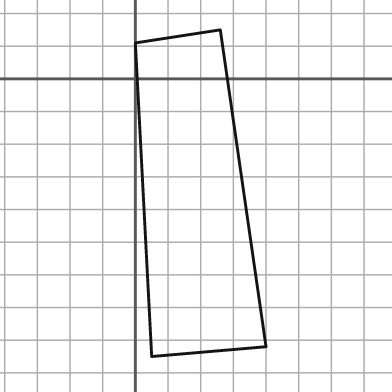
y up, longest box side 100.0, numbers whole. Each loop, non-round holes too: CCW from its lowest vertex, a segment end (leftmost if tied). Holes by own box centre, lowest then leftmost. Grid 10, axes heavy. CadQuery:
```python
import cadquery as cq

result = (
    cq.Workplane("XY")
    .moveTo(5.0, -85.0)
    .lineTo(40.0, -82.0)
    .lineTo(26.0, 15.0)
    .lineTo(0.0, 11.0)
    .close()
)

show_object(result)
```